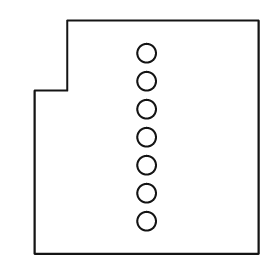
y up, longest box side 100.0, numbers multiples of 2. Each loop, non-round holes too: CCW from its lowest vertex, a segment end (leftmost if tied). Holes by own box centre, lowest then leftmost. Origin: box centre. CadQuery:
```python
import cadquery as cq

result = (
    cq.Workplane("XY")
    .moveTo(-48.0, -50.0)
    .lineTo(48.0, -50.0)
    .lineTo(48.0, 50.0)
    .lineTo(-34.0, 50.0)
    .lineTo(-34.0, 20.0)
    .lineTo(-48.0, 20.0)
    .close()
    .moveTo(0.0, -36.0)
    .circle(4.0)
    .moveTo(0.0, -24.0)
    .circle(4.0)
    .moveTo(0.0, -12.0)
    .circle(4.0)
    .moveTo(0.0, 0.0)
    .circle(4.0)
    .moveTo(0.0, 12.0)
    .circle(4.0)
    .moveTo(0.0, 24.0)
    .circle(4.0)
    .moveTo(0.0, 36.0)
    .circle(4.0)
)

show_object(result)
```